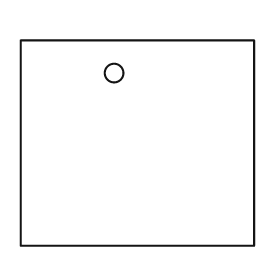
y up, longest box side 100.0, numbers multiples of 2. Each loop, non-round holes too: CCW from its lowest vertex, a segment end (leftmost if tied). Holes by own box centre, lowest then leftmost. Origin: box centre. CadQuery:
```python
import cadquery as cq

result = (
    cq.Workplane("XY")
    .moveTo(-50.0, -44.0)
    .lineTo(50.0, -44.0)
    .lineTo(50.0, 44.0)
    .lineTo(-50.0, 44.0)
    .close()
    .moveTo(-10.0, 30.0)
    .circle(4.0)
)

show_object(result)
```